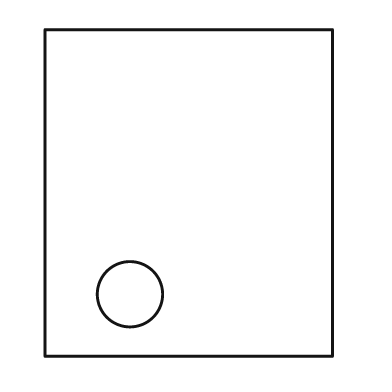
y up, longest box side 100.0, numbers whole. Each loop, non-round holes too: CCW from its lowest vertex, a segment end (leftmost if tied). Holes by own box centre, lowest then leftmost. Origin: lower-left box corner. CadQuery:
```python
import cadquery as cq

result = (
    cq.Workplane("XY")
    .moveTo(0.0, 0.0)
    .lineTo(88.0, 0.0)
    .lineTo(88.0, 100.0)
    .lineTo(0.0, 100.0)
    .close()
    .moveTo(26.0, 19.0)
    .circle(10.0)
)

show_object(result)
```